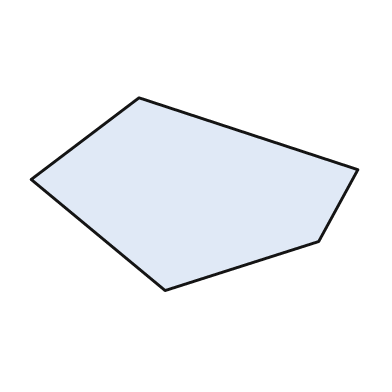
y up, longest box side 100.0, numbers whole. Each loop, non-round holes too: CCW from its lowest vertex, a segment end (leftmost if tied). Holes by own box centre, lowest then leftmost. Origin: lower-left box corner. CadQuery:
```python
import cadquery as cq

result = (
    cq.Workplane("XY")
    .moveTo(41.0, 0.0)
    .lineTo(88.0, 15.0)
    .lineTo(100.0, 37.0)
    .lineTo(33.0, 59.0)
    .lineTo(0.0, 34.0)
    .close()
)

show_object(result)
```